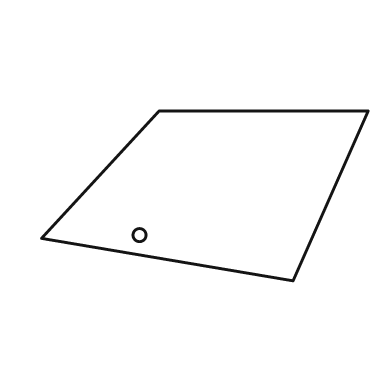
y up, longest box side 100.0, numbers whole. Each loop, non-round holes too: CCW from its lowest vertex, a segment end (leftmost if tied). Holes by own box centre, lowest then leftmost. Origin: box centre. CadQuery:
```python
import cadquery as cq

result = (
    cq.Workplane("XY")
    .moveTo(27.0, -26.0)
    .lineTo(50.0, 26.0)
    .lineTo(-14.0, 26.0)
    .lineTo(-50.0, -13.0)
    .close()
    .moveTo(-20.0, -12.0)
    .circle(2.0)
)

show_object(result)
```